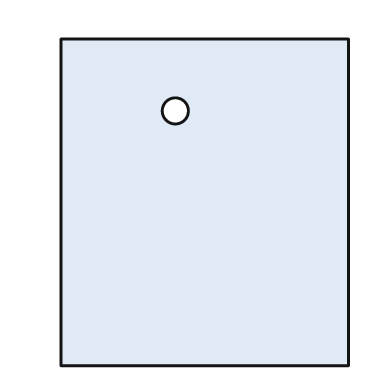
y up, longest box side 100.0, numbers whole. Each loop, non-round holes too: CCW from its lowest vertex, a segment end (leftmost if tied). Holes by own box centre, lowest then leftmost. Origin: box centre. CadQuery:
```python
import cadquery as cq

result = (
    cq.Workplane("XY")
    .moveTo(-44.0, -50.0)
    .lineTo(44.0, -50.0)
    .lineTo(44.0, 50.0)
    .lineTo(-44.0, 50.0)
    .close()
    .moveTo(-9.0, 28.0)
    .circle(4.0)
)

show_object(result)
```